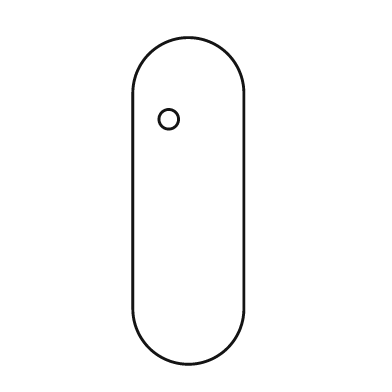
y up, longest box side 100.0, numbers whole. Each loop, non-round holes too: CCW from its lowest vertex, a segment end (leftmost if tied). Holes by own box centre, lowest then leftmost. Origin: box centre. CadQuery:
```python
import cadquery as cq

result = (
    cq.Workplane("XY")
    .moveTo(-17.0, -33.0)
    .threePointArc((0.0, -50.0), (17.0, -33.0))
    .lineTo(17.0, 33.0)
    .threePointArc((0.0, 50.0), (-17.0, 33.0))
    .close()
    .moveTo(-6.0, 25.0)
    .circle(3.0)
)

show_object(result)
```